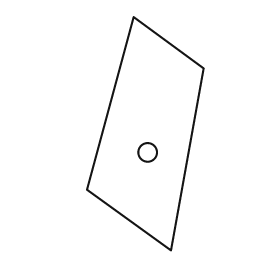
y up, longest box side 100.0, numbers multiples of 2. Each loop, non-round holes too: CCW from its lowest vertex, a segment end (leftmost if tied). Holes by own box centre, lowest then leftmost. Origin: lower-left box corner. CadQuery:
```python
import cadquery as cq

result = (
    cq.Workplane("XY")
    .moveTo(36.0, 0.0)
    .lineTo(50.0, 78.0)
    .lineTo(20.0, 100.0)
    .lineTo(0.0, 26.0)
    .close()
    .moveTo(26.0, 42.0)
    .circle(4.0)
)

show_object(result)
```